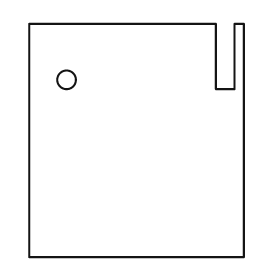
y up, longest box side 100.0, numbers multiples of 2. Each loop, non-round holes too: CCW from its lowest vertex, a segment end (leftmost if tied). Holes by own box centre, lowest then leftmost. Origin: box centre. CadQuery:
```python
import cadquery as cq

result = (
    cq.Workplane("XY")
    .moveTo(-46.0, -50.0)
    .lineTo(46.0, -50.0)
    .lineTo(46.0, 50.0)
    .lineTo(42.0, 50.0)
    .lineTo(42.0, 22.0)
    .lineTo(34.0, 22.0)
    .lineTo(34.0, 50.0)
    .lineTo(-46.0, 50.0)
    .close()
    .moveTo(-30.0, 26.0)
    .circle(4.0)
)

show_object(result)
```